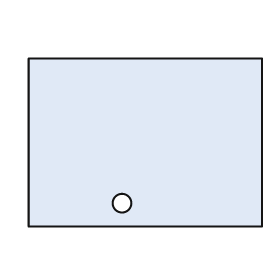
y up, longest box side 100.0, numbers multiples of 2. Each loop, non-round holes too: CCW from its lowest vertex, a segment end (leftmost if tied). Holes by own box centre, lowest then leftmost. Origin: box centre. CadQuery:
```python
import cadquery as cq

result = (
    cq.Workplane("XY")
    .moveTo(-50.0, -36.0)
    .lineTo(50.0, -36.0)
    .lineTo(50.0, 36.0)
    .lineTo(-50.0, 36.0)
    .close()
    .moveTo(-10.0, -26.0)
    .circle(4.0)
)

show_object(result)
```